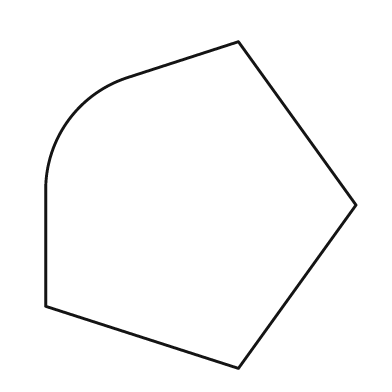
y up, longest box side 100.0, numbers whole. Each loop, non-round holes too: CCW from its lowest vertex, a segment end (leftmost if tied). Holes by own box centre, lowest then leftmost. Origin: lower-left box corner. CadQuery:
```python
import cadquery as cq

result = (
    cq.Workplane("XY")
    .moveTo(59.0, 0.0)
    .lineTo(95.0, 50.0)
    .lineTo(59.0, 100.0)
    .lineTo(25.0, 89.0)
    .threePointArc((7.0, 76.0), (0.0, 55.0))
    .lineTo(0.0, 19.0)
    .close()
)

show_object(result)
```